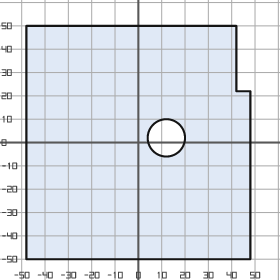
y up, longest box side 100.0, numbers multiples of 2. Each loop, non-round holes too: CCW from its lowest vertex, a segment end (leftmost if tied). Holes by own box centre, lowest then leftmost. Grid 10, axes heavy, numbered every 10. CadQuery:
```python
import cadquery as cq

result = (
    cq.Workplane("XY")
    .moveTo(-48.0, -50.0)
    .lineTo(48.0, -50.0)
    .lineTo(48.0, 22.0)
    .lineTo(42.0, 22.0)
    .lineTo(42.0, 50.0)
    .lineTo(-48.0, 50.0)
    .close()
    .moveTo(12.0, 2.0)
    .circle(8.0)
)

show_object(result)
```